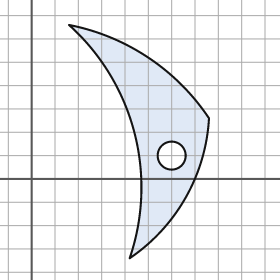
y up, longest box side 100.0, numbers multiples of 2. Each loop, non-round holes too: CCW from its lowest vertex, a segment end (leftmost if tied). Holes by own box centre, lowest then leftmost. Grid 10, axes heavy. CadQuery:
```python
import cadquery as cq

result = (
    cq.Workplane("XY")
    .moveTo(42.0, -34.0)
    .threePointArc((66.0, -8.0), (76.0, 26.0))
    .threePointArc((50.0, 52.0), (16.0, 66.0))
    .threePointArc((44.0, 20.0), (42.0, -34.0))
    .close()
    .moveTo(60.0, 10.0)
    .circle(6.0)
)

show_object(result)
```